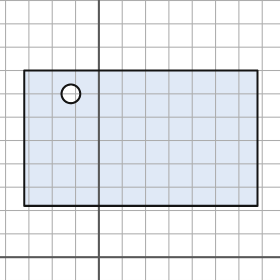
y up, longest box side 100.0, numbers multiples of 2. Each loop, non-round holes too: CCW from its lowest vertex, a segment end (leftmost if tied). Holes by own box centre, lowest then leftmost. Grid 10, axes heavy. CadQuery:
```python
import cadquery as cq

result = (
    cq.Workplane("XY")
    .moveTo(-32.0, 22.0)
    .lineTo(68.0, 22.0)
    .lineTo(68.0, 80.0)
    .lineTo(-32.0, 80.0)
    .close()
    .moveTo(-12.0, 70.0)
    .circle(4.0)
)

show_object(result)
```